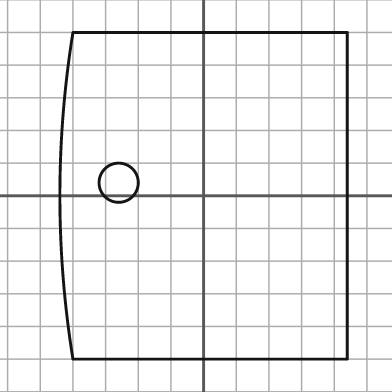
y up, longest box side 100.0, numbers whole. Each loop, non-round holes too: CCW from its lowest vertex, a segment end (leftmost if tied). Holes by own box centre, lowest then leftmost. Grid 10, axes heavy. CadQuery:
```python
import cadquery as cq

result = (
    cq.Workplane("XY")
    .moveTo(-40.0, -50.0)
    .lineTo(44.0, -50.0)
    .lineTo(44.0, 50.0)
    .lineTo(-40.0, 50.0)
    .threePointArc((-44.0, 0.0), (-40.0, -50.0))
    .close()
    .moveTo(-26.0, 4.0)
    .circle(6.0)
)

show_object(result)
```